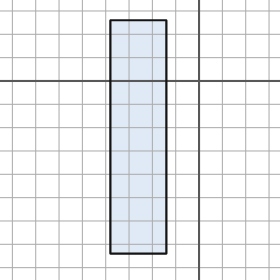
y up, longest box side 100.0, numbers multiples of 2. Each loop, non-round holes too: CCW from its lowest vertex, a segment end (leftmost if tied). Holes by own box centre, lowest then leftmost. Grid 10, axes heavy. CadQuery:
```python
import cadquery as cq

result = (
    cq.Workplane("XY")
    .moveTo(-38.0, -74.0)
    .lineTo(-14.0, -74.0)
    .lineTo(-14.0, 26.0)
    .lineTo(-38.0, 26.0)
    .close()
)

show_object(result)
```